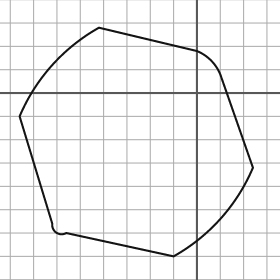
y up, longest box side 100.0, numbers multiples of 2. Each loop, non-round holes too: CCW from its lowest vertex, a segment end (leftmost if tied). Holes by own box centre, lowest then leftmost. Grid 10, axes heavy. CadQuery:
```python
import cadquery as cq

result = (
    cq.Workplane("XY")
    .moveTo(-10.0, -70.0)
    .threePointArc((10.0, -54.0), (24.0, -32.0))
    .lineTo(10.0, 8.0)
    .threePointArc((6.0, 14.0), (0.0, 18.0))
    .lineTo(-42.0, 28.0)
    .threePointArc((-62.0, 12.0), (-76.0, -10.0))
    .lineTo(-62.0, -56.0)
    .threePointArc((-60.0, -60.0), (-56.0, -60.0))
    .close()
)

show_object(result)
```